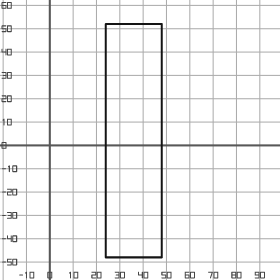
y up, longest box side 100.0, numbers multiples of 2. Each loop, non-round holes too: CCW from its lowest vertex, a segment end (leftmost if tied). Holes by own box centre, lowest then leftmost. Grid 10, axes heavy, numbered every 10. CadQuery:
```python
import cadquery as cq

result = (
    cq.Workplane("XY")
    .moveTo(24.0, -48.0)
    .lineTo(48.0, -48.0)
    .lineTo(48.0, 52.0)
    .lineTo(24.0, 52.0)
    .close()
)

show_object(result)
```